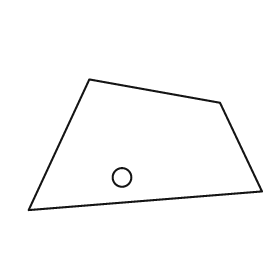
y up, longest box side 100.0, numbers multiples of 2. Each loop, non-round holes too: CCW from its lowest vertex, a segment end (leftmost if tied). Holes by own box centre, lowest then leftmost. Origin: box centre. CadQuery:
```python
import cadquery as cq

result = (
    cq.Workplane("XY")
    .moveTo(-50.0, -28.0)
    .lineTo(50.0, -20.0)
    .lineTo(32.0, 18.0)
    .lineTo(-24.0, 28.0)
    .close()
    .moveTo(-10.0, -14.0)
    .circle(4.0)
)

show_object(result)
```